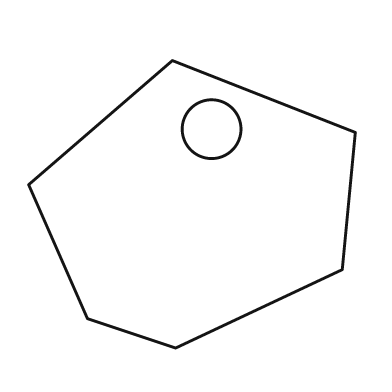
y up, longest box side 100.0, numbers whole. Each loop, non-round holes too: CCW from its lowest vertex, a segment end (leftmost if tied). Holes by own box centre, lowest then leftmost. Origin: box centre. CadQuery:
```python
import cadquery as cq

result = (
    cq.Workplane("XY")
    .moveTo(-5.0, -44.0)
    .lineTo(46.0, -20.0)
    .lineTo(50.0, 22.0)
    .lineTo(-6.0, 44.0)
    .lineTo(-50.0, 6.0)
    .lineTo(-32.0, -35.0)
    .close()
    .moveTo(6.0, 23.0)
    .circle(9.0)
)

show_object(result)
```